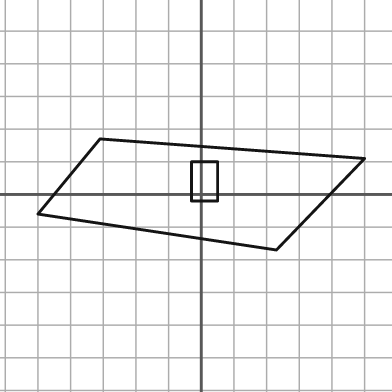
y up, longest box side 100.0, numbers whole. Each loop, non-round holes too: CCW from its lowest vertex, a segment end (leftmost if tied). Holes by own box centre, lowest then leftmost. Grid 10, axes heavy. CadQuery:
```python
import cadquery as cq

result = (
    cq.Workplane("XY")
    .moveTo(23.0, -17.0)
    .lineTo(50.0, 11.0)
    .lineTo(-31.0, 17.0)
    .lineTo(-50.0, -6.0)
    .close()
    .moveTo(-3.0, -2.0)
    .lineTo(5.0, -2.0)
    .lineTo(5.0, 10.0)
    .lineTo(-3.0, 10.0)
    .close()
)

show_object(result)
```